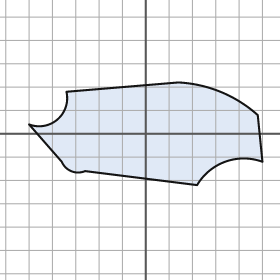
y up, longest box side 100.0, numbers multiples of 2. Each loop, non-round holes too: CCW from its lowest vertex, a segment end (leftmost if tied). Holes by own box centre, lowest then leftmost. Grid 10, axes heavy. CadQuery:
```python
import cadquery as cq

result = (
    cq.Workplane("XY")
    .moveTo(22.0, -22.0)
    .threePointArc((34.0, -12.0), (50.0, -12.0))
    .lineTo(48.0, 8.0)
    .threePointArc((32.0, 18.0), (14.0, 22.0))
    .lineTo(-34.0, 18.0)
    .threePointArc((-38.0, 6.0), (-50.0, 4.0))
    .lineTo(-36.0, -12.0)
    .threePointArc((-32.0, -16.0), (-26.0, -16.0))
    .close()
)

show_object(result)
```